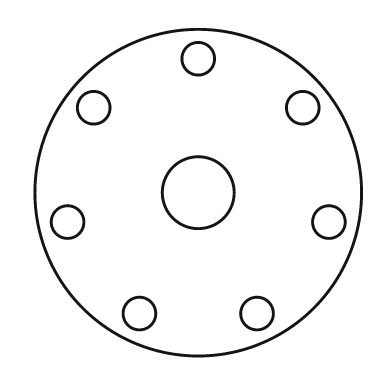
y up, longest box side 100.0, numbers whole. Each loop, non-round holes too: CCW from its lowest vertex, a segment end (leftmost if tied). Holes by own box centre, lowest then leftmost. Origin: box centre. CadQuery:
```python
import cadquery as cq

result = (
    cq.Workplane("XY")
    .moveTo(0.0, 0.0)
    .circle(50.0)
    .moveTo(-18.0, -37.0)
    .circle(5.0)
    .moveTo(18.0, -37.0)
    .circle(5.0)
    .moveTo(-40.0, -9.0)
    .circle(5.0)
    .moveTo(40.0, -9.0)
    .circle(5.0)
    .moveTo(0.0, 0.0)
    .circle(11.0)
    .moveTo(-32.0, 26.0)
    .circle(5.0)
    .moveTo(32.0, 26.0)
    .circle(5.0)
    .moveTo(0.0, 41.0)
    .circle(5.0)
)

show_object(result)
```